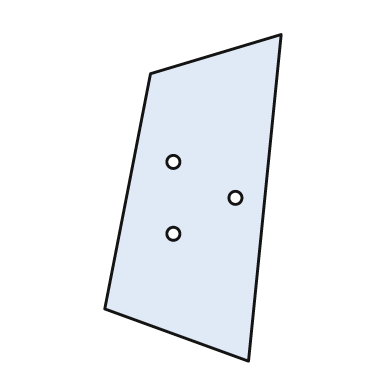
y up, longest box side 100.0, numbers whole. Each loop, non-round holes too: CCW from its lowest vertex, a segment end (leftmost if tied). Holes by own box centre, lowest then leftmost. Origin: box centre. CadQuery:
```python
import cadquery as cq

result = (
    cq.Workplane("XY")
    .moveTo(17.0, -50.0)
    .lineTo(27.0, 50.0)
    .lineTo(-13.0, 38.0)
    .lineTo(-27.0, -34.0)
    .close()
    .moveTo(-6.0, -11.0)
    .circle(2.0)
    .moveTo(13.0, 0.0)
    .circle(2.0)
    .moveTo(-6.0, 11.0)
    .circle(2.0)
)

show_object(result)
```